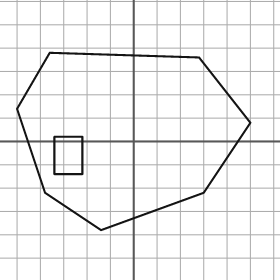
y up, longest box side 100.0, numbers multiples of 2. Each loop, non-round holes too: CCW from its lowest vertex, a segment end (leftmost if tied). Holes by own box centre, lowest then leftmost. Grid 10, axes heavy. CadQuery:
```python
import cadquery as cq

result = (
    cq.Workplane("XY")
    .moveTo(-14.0, -38.0)
    .lineTo(30.0, -22.0)
    .lineTo(50.0, 8.0)
    .lineTo(28.0, 36.0)
    .lineTo(-36.0, 38.0)
    .lineTo(-50.0, 14.0)
    .lineTo(-38.0, -22.0)
    .close()
    .moveTo(-34.0, -14.0)
    .lineTo(-22.0, -14.0)
    .lineTo(-22.0, 2.0)
    .lineTo(-34.0, 2.0)
    .close()
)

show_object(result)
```